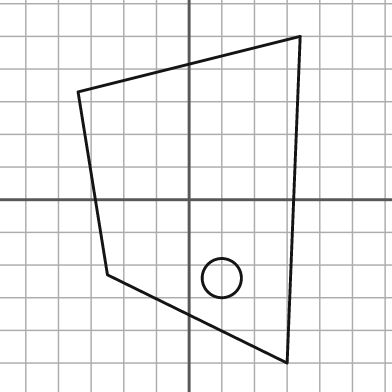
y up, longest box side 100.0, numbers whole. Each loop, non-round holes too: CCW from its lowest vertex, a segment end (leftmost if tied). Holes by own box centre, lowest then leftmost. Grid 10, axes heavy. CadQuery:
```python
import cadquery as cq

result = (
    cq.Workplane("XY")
    .moveTo(30.0, -50.0)
    .lineTo(34.0, 50.0)
    .lineTo(-34.0, 33.0)
    .lineTo(-25.0, -23.0)
    .close()
    .moveTo(10.0, -24.0)
    .circle(6.0)
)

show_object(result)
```